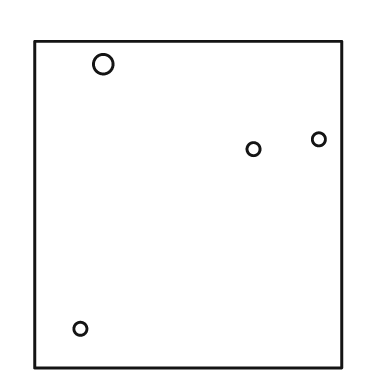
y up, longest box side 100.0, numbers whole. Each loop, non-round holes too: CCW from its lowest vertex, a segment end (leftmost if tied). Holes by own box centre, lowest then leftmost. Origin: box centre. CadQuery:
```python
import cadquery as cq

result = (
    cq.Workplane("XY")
    .moveTo(-47.0, -50.0)
    .lineTo(47.0, -50.0)
    .lineTo(47.0, 50.0)
    .lineTo(-47.0, 50.0)
    .close()
    .moveTo(-33.0, -38.0)
    .circle(2.0)
    .moveTo(20.0, 17.0)
    .circle(2.0)
    .moveTo(40.0, 20.0)
    .circle(2.0)
    .moveTo(-26.0, 43.0)
    .circle(3.0)
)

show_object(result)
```